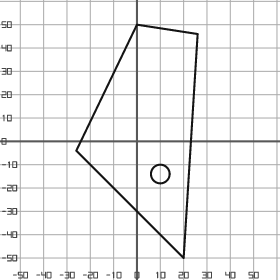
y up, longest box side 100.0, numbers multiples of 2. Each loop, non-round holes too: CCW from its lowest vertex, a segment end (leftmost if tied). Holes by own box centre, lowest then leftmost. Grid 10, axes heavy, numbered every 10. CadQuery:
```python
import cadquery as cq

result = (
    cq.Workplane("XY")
    .moveTo(20.0, -50.0)
    .lineTo(26.0, 46.0)
    .lineTo(0.0, 50.0)
    .lineTo(-26.0, -4.0)
    .close()
    .moveTo(10.0, -14.0)
    .circle(4.0)
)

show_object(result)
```